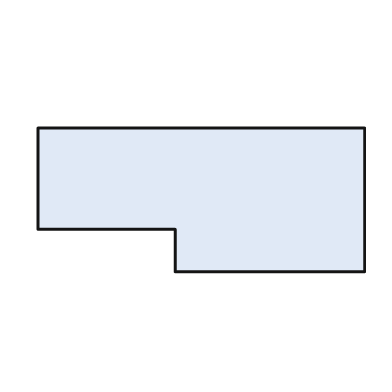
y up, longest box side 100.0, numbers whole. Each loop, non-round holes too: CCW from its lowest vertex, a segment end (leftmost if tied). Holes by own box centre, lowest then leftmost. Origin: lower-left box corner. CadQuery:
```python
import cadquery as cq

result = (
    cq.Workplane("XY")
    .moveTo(42.0, 0.0)
    .lineTo(100.0, 0.0)
    .lineTo(100.0, 44.0)
    .lineTo(0.0, 44.0)
    .lineTo(0.0, 13.0)
    .lineTo(42.0, 13.0)
    .close()
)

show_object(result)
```